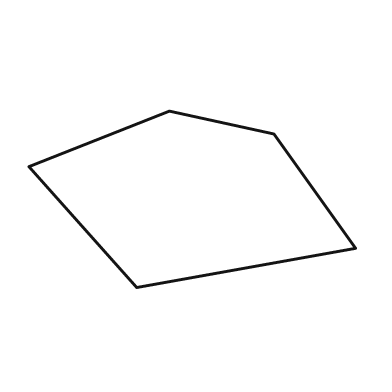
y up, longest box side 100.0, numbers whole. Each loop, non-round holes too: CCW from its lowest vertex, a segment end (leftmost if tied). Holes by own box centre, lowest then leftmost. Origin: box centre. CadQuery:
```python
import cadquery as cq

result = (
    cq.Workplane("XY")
    .moveTo(-17.0, -27.0)
    .lineTo(50.0, -15.0)
    .lineTo(25.0, 20.0)
    .lineTo(-7.0, 27.0)
    .lineTo(-50.0, 10.0)
    .close()
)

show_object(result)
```